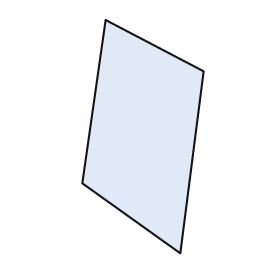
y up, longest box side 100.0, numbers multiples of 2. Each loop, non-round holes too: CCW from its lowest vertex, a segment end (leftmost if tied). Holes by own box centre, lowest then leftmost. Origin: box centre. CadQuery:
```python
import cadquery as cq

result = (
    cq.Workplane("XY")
    .moveTo(16.0, -50.0)
    .lineTo(26.0, 28.0)
    .lineTo(-16.0, 50.0)
    .lineTo(-26.0, -20.0)
    .close()
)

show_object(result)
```